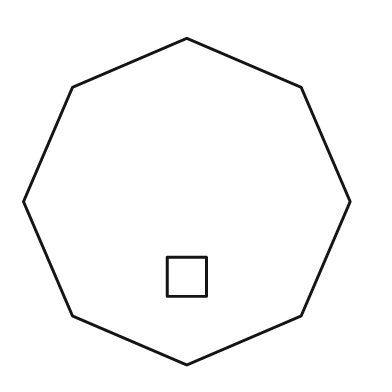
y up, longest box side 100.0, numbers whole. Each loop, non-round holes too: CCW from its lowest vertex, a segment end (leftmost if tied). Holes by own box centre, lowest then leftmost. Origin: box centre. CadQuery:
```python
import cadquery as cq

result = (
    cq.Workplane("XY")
    .moveTo(0.0, -50.0)
    .lineTo(35.0, -35.0)
    .lineTo(50.0, 0.0)
    .lineTo(35.0, 35.0)
    .lineTo(0.0, 50.0)
    .lineTo(-35.0, 35.0)
    .lineTo(-50.0, 0.0)
    .lineTo(-35.0, -35.0)
    .close()
    .moveTo(-6.0, -29.0)
    .lineTo(6.0, -29.0)
    .lineTo(6.0, -17.0)
    .lineTo(-6.0, -17.0)
    .close()
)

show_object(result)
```